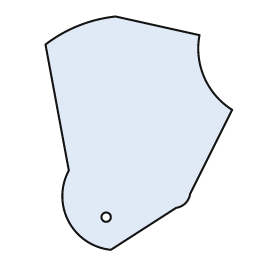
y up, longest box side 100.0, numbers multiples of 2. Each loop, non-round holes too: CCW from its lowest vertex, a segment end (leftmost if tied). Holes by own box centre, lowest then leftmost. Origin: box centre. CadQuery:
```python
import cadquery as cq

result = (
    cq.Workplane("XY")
    .moveTo(-12.0, -50.0)
    .lineTo(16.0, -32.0)
    .threePointArc((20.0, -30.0), (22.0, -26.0))
    .lineTo(40.0, 10.0)
    .threePointArc((28.0, 24.0), (26.0, 42.0))
    .lineTo(-10.0, 50.0)
    .threePointArc((-26.0, 46.0), (-40.0, 38.0))
    .lineTo(-30.0, -16.0)
    .threePointArc((-30.0, -38.0), (-12.0, -50.0))
    .close()
    .moveTo(-14.0, -36.0)
    .circle(2.0)
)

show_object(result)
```